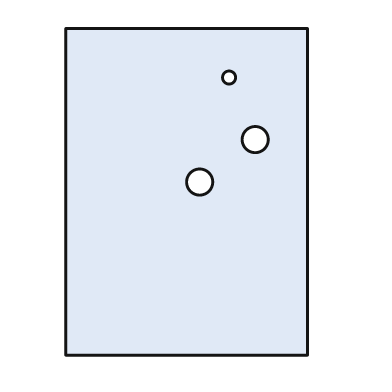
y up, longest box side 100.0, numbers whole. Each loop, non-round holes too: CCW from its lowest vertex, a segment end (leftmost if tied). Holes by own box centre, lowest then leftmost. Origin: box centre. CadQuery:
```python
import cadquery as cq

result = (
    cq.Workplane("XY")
    .moveTo(-37.0, -50.0)
    .lineTo(37.0, -50.0)
    .lineTo(37.0, 50.0)
    .lineTo(-37.0, 50.0)
    .close()
    .moveTo(4.0, 3.0)
    .circle(4.0)
    .moveTo(21.0, 16.0)
    .circle(4.0)
    .moveTo(13.0, 35.0)
    .circle(2.0)
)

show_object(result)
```